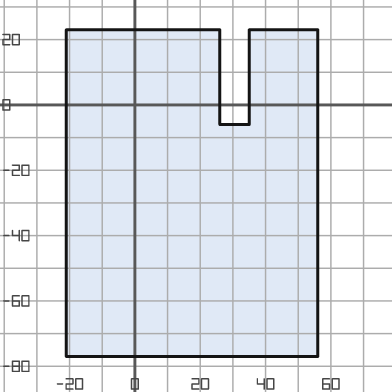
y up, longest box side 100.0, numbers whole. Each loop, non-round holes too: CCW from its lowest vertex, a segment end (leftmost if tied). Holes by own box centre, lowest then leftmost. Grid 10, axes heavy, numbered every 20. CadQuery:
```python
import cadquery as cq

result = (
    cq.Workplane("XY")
    .moveTo(-21.0, -77.0)
    .lineTo(56.0, -77.0)
    .lineTo(56.0, 23.0)
    .lineTo(35.0, 23.0)
    .lineTo(35.0, -6.0)
    .lineTo(26.0, -6.0)
    .lineTo(26.0, 23.0)
    .lineTo(-21.0, 23.0)
    .close()
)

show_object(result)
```